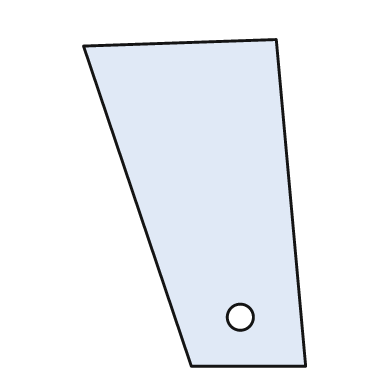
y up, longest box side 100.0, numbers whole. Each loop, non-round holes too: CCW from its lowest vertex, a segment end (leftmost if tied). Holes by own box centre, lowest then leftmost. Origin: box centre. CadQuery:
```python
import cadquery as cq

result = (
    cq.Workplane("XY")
    .moveTo(-1.0, -50.0)
    .lineTo(34.0, -50.0)
    .lineTo(25.0, 50.0)
    .lineTo(-34.0, 48.0)
    .close()
    .moveTo(14.0, -35.0)
    .circle(4.0)
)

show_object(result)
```